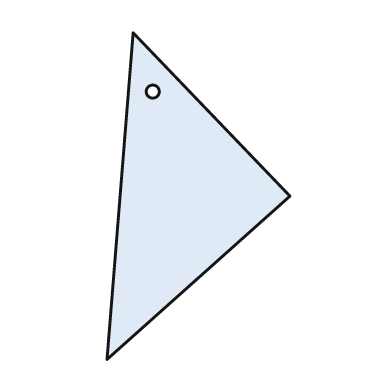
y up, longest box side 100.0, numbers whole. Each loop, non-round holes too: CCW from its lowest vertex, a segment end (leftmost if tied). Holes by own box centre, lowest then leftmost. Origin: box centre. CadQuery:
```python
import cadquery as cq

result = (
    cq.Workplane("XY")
    .moveTo(-28.0, -50.0)
    .lineTo(28.0, 0.0)
    .lineTo(-20.0, 50.0)
    .close()
    .moveTo(-14.0, 32.0)
    .circle(2.0)
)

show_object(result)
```